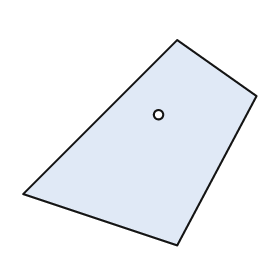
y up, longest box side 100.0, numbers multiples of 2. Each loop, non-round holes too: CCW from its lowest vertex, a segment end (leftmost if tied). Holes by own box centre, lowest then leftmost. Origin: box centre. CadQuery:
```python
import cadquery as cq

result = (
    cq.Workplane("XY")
    .moveTo(16.0, -44.0)
    .lineTo(50.0, 20.0)
    .lineTo(16.0, 44.0)
    .lineTo(-50.0, -22.0)
    .close()
    .moveTo(8.0, 12.0)
    .circle(2.0)
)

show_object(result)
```